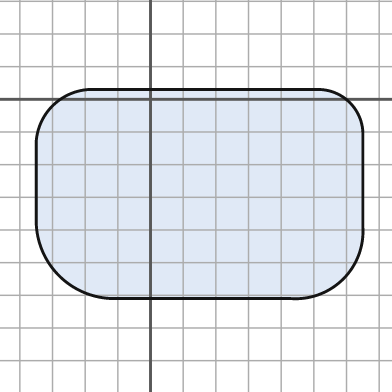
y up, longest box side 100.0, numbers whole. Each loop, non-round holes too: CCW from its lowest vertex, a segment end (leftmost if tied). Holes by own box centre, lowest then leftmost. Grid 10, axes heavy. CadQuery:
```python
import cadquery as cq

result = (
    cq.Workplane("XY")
    .moveTo(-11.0, -61.0)
    .lineTo(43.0, -61.0)
    .threePointArc((59.0, -55.0), (65.0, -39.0))
    .lineTo(65.0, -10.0)
    .threePointArc((61.0, -1.0), (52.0, 3.0))
    .lineTo(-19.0, 3.0)
    .threePointArc((-30.0, -2.0), (-35.0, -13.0))
    .lineTo(-35.0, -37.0)
    .threePointArc((-28.0, -54.0), (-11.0, -61.0))
    .close()
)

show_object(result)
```